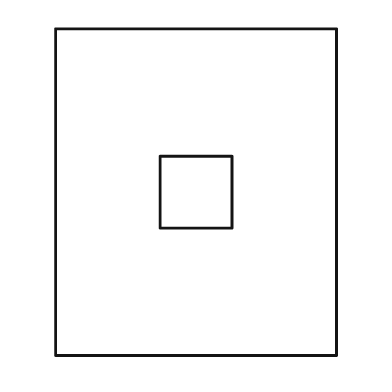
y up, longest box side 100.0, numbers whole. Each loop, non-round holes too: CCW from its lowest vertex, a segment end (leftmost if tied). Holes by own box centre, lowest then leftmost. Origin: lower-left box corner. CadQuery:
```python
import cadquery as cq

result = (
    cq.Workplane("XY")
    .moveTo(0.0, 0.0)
    .lineTo(86.0, 0.0)
    .lineTo(86.0, 100.0)
    .lineTo(0.0, 100.0)
    .close()
    .moveTo(32.0, 39.0)
    .lineTo(54.0, 39.0)
    .lineTo(54.0, 61.0)
    .lineTo(32.0, 61.0)
    .close()
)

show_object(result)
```